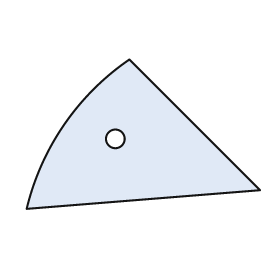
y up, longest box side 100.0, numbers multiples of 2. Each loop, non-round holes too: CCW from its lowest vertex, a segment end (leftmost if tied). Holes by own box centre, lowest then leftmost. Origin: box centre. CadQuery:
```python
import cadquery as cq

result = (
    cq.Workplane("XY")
    .moveTo(-50.0, -32.0)
    .lineTo(50.0, -24.0)
    .lineTo(-6.0, 32.0)
    .threePointArc((-34.0, 4.0), (-50.0, -32.0))
    .close()
    .moveTo(-12.0, -2.0)
    .circle(4.0)
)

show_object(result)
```